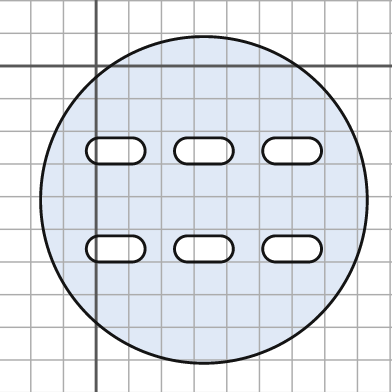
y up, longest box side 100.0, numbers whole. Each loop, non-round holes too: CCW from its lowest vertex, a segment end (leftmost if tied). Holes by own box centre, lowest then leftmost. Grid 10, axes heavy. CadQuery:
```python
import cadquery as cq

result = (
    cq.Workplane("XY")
    .moveTo(33.0, -41.0)
    .circle(50.0)
    .moveTo(1.0, -60.0)
    .lineTo(11.0, -60.0)
    .threePointArc((15.0, -56.0), (11.0, -52.0))
    .lineTo(1.0, -52.0)
    .threePointArc((-3.0, -56.0), (1.0, -60.0))
    .close()
    .moveTo(28.0, -60.0)
    .lineTo(38.0, -60.0)
    .threePointArc((42.0, -56.0), (38.0, -52.0))
    .lineTo(28.0, -52.0)
    .threePointArc((24.0, -56.0), (28.0, -60.0))
    .close()
    .moveTo(55.0, -60.0)
    .lineTo(65.0, -60.0)
    .threePointArc((69.0, -56.0), (65.0, -52.0))
    .lineTo(55.0, -52.0)
    .threePointArc((51.0, -56.0), (55.0, -60.0))
    .close()
    .moveTo(1.0, -30.0)
    .lineTo(11.0, -30.0)
    .threePointArc((15.0, -26.0), (11.0, -22.0))
    .lineTo(1.0, -22.0)
    .threePointArc((-3.0, -26.0), (1.0, -30.0))
    .close()
    .moveTo(28.0, -30.0)
    .lineTo(38.0, -30.0)
    .threePointArc((42.0, -26.0), (38.0, -22.0))
    .lineTo(28.0, -22.0)
    .threePointArc((24.0, -26.0), (28.0, -30.0))
    .close()
    .moveTo(55.0, -30.0)
    .lineTo(65.0, -30.0)
    .threePointArc((69.0, -26.0), (65.0, -22.0))
    .lineTo(55.0, -22.0)
    .threePointArc((51.0, -26.0), (55.0, -30.0))
    .close()
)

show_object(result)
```